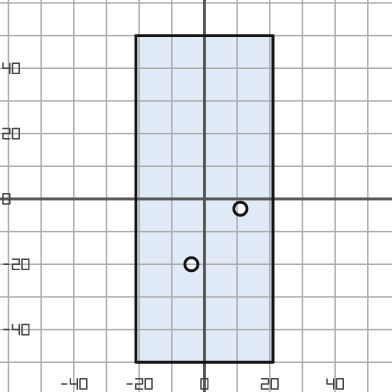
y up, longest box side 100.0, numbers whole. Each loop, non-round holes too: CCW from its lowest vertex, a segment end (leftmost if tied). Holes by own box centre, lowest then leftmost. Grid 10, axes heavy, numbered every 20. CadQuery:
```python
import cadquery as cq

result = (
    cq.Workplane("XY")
    .moveTo(-21.0, -50.0)
    .lineTo(21.0, -50.0)
    .lineTo(21.0, 50.0)
    .lineTo(-21.0, 50.0)
    .close()
    .moveTo(-4.0, -20.0)
    .circle(2.0)
    .moveTo(11.0, -3.0)
    .circle(2.0)
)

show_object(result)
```